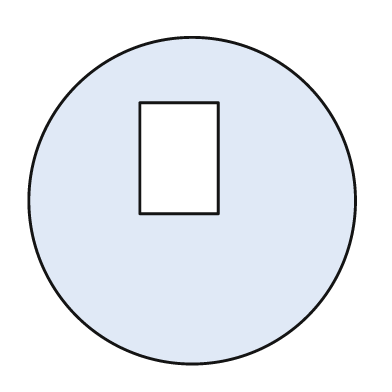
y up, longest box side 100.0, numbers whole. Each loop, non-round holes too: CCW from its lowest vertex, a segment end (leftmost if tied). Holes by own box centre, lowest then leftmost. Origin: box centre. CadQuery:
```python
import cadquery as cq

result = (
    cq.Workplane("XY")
    .moveTo(0.0, 0.0)
    .circle(50.0)
    .moveTo(-16.0, -4.0)
    .lineTo(8.0, -4.0)
    .lineTo(8.0, 30.0)
    .lineTo(-16.0, 30.0)
    .close()
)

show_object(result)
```